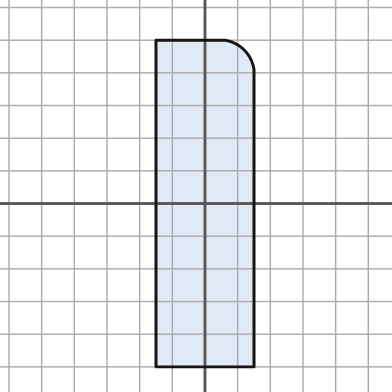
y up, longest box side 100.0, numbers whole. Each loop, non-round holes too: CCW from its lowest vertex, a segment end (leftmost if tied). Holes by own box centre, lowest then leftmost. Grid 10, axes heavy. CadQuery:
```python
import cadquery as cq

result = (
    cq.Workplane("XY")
    .moveTo(-15.0, -50.0)
    .lineTo(15.0, -50.0)
    .lineTo(15.0, 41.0)
    .threePointArc((12.0, 47.0), (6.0, 50.0))
    .lineTo(-15.0, 50.0)
    .close()
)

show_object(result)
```